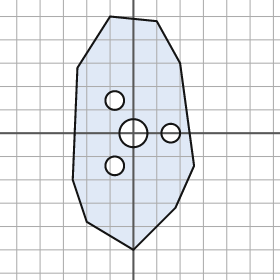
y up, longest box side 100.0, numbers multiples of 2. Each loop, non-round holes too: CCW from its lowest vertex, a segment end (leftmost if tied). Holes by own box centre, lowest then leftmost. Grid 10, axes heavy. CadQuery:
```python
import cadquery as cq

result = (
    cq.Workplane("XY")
    .moveTo(0.0, -50.0)
    .lineTo(18.0, -32.0)
    .lineTo(26.0, -14.0)
    .lineTo(20.0, 30.0)
    .lineTo(10.0, 48.0)
    .lineTo(-10.0, 50.0)
    .lineTo(-24.0, 28.0)
    .lineTo(-26.0, -20.0)
    .lineTo(-20.0, -38.0)
    .close()
    .moveTo(-8.0, -14.0)
    .circle(4.0)
    .moveTo(0.0, 0.0)
    .circle(6.0)
    .moveTo(16.0, 0.0)
    .circle(4.0)
    .moveTo(-8.0, 14.0)
    .circle(4.0)
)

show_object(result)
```